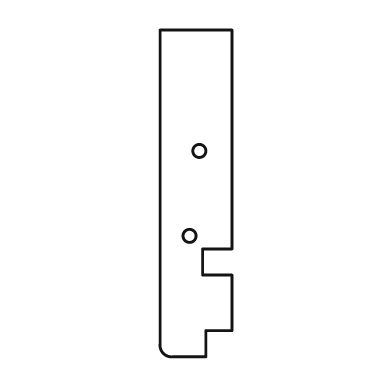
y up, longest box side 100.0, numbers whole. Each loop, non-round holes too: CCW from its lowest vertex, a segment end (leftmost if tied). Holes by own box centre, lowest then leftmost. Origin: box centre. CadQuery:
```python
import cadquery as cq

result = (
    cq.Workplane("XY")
    .moveTo(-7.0, -50.0)
    .lineTo(3.0, -50.0)
    .lineTo(3.0, -42.0)
    .lineTo(11.0, -42.0)
    .lineTo(11.0, -25.0)
    .lineTo(2.0, -25.0)
    .lineTo(2.0, -17.0)
    .lineTo(11.0, -17.0)
    .lineTo(11.0, 50.0)
    .lineTo(-11.0, 50.0)
    .lineTo(-11.0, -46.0)
    .threePointArc((-10.0, -49.0), (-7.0, -50.0))
    .close()
    .moveTo(-2.0, -13.0)
    .circle(2.0)
    .moveTo(1.0, 13.0)
    .circle(2.0)
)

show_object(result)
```